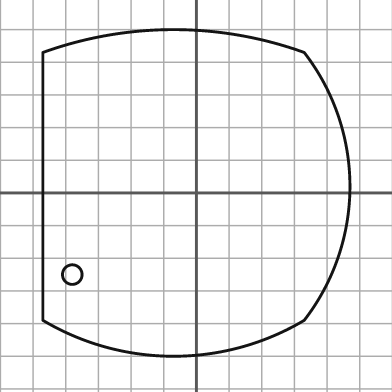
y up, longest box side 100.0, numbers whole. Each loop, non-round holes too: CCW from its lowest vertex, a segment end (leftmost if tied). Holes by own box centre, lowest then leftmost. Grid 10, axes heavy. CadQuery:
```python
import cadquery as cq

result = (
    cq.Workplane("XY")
    .moveTo(-47.0, -39.0)
    .threePointArc((-7.0, -50.0), (33.0, -39.0))
    .threePointArc((47.0, 2.0), (33.0, 43.0))
    .threePointArc((-7.0, 50.0), (-47.0, 43.0))
    .close()
    .moveTo(-38.0, -25.0)
    .circle(3.0)
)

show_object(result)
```